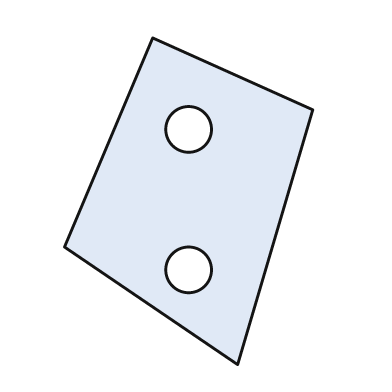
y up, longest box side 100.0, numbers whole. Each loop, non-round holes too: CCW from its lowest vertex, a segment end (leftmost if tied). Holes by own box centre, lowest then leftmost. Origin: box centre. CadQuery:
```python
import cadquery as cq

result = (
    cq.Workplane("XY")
    .moveTo(15.0, -50.0)
    .lineTo(38.0, 28.0)
    .lineTo(-11.0, 50.0)
    .lineTo(-38.0, -14.0)
    .close()
    .moveTo(0.0, -21.0)
    .circle(7.0)
    .moveTo(0.0, 22.0)
    .circle(7.0)
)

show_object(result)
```